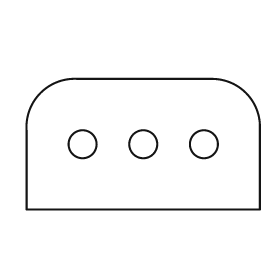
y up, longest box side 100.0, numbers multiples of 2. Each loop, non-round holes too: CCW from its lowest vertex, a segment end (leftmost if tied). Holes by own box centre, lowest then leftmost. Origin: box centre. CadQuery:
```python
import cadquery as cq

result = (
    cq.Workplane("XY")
    .moveTo(-50.0, -28.0)
    .lineTo(50.0, -28.0)
    .lineTo(50.0, 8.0)
    .threePointArc((44.0, 22.0), (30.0, 28.0))
    .lineTo(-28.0, 28.0)
    .threePointArc((-44.0, 22.0), (-50.0, 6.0))
    .close()
    .moveTo(-26.0, 0.0)
    .circle(6.0)
    .moveTo(0.0, 0.0)
    .circle(6.0)
    .moveTo(26.0, 0.0)
    .circle(6.0)
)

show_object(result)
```